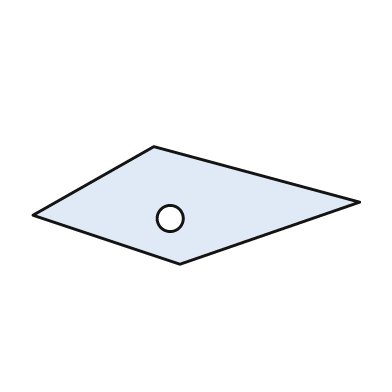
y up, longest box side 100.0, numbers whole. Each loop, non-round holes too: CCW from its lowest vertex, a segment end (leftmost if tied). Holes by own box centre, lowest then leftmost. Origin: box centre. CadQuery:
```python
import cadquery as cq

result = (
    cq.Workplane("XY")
    .moveTo(-5.0, -18.0)
    .lineTo(50.0, 1.0)
    .lineTo(-13.0, 18.0)
    .lineTo(-50.0, -3.0)
    .close()
    .moveTo(-8.0, -4.0)
    .circle(4.0)
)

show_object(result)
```